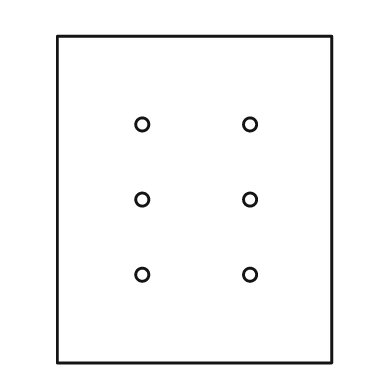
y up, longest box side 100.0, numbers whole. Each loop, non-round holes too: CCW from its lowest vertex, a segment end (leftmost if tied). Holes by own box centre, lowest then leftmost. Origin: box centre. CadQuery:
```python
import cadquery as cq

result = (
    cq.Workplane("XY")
    .moveTo(-42.0, -50.0)
    .lineTo(42.0, -50.0)
    .lineTo(42.0, 50.0)
    .lineTo(-42.0, 50.0)
    .close()
    .moveTo(-16.0, -23.0)
    .circle(2.0)
    .moveTo(17.0, -23.0)
    .circle(2.0)
    .moveTo(-16.0, 0.0)
    .circle(2.0)
    .moveTo(17.0, 0.0)
    .circle(2.0)
    .moveTo(-16.0, 23.0)
    .circle(2.0)
    .moveTo(17.0, 23.0)
    .circle(2.0)
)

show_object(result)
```